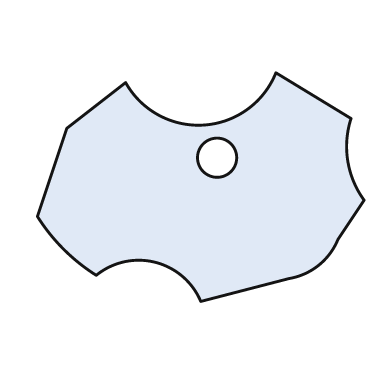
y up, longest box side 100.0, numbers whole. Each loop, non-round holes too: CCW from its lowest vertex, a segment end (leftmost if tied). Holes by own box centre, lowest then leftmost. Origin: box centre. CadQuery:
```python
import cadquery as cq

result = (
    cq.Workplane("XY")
    .moveTo(0.0, -35.0)
    .lineTo(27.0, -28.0)
    .threePointArc((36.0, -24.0), (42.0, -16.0))
    .lineTo(50.0, -4.0)
    .threePointArc((45.0, 8.0), (46.0, 21.0))
    .lineTo(23.0, 35.0)
    .threePointArc((1.0, 19.0), (-23.0, 32.0))
    .lineTo(-41.0, 18.0)
    .lineTo(-50.0, -9.0)
    .threePointArc((-42.0, -19.0), (-32.0, -27.0))
    .threePointArc((-14.0, -23.0), (0.0, -35.0))
    .close()
    .moveTo(5.0, 9.0)
    .circle(6.0)
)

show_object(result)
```